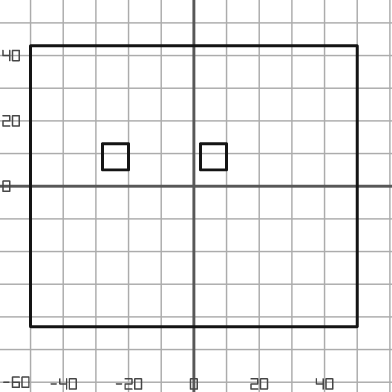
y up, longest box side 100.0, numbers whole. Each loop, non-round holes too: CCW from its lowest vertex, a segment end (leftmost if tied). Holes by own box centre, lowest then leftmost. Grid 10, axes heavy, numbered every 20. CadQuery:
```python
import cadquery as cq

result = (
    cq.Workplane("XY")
    .moveTo(-50.0, -43.0)
    .lineTo(50.0, -43.0)
    .lineTo(50.0, 43.0)
    .lineTo(-50.0, 43.0)
    .close()
    .moveTo(-28.0, 5.0)
    .lineTo(-20.0, 5.0)
    .lineTo(-20.0, 13.0)
    .lineTo(-28.0, 13.0)
    .close()
    .moveTo(2.0, 5.0)
    .lineTo(10.0, 5.0)
    .lineTo(10.0, 13.0)
    .lineTo(2.0, 13.0)
    .close()
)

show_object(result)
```